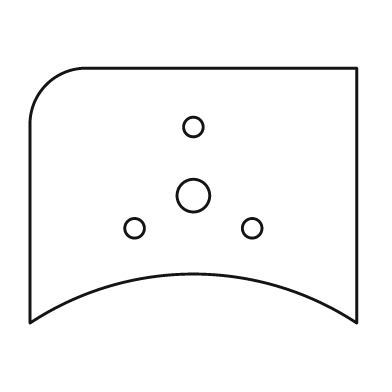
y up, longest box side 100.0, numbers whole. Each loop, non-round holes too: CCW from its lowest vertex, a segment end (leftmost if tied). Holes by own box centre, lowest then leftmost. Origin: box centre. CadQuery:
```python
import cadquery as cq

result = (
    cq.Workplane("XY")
    .moveTo(-50.0, -39.0)
    .threePointArc((0.0, -24.0), (50.0, -39.0))
    .lineTo(50.0, 39.0)
    .lineTo(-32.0, 39.0)
    .threePointArc((-45.0, 34.0), (-50.0, 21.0))
    .close()
    .moveTo(-18.0, -10.0)
    .circle(3.0)
    .moveTo(18.0, -10.0)
    .circle(3.0)
    .moveTo(0.0, 0.0)
    .circle(5.0)
    .moveTo(0.0, 21.0)
    .circle(3.0)
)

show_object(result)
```